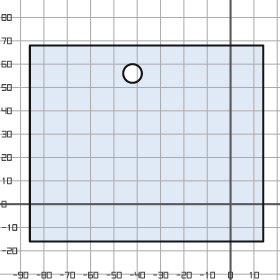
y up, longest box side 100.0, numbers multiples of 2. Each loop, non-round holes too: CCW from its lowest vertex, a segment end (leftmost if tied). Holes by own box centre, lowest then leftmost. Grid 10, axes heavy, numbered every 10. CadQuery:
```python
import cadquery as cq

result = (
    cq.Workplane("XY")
    .moveTo(-86.0, -16.0)
    .lineTo(14.0, -16.0)
    .lineTo(14.0, 68.0)
    .lineTo(-86.0, 68.0)
    .close()
    .moveTo(-42.0, 56.0)
    .circle(4.0)
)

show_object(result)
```